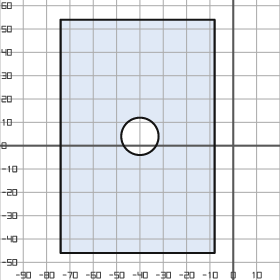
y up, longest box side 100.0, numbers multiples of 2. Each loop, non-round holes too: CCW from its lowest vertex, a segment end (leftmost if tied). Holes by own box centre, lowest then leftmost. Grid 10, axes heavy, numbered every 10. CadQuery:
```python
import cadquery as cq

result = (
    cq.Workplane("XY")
    .moveTo(-74.0, -46.0)
    .lineTo(-8.0, -46.0)
    .lineTo(-8.0, 54.0)
    .lineTo(-74.0, 54.0)
    .close()
    .moveTo(-40.0, 4.0)
    .circle(8.0)
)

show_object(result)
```